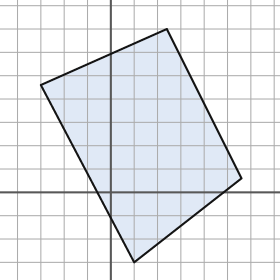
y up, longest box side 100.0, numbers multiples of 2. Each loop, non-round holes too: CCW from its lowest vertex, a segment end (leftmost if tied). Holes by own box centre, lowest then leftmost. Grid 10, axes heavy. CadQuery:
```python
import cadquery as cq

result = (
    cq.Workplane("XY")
    .moveTo(10.0, -30.0)
    .lineTo(56.0, 6.0)
    .lineTo(24.0, 70.0)
    .lineTo(-30.0, 46.0)
    .close()
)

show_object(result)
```